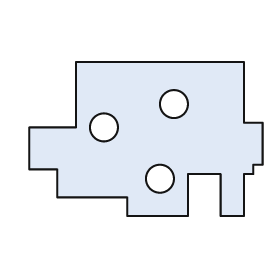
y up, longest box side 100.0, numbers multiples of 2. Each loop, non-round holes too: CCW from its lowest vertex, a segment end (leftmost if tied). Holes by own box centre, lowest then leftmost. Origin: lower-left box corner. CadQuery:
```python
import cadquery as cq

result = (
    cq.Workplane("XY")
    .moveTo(42.0, 0.0)
    .lineTo(68.0, 0.0)
    .lineTo(68.0, 18.0)
    .lineTo(82.0, 18.0)
    .lineTo(82.0, 0.0)
    .lineTo(92.0, 0.0)
    .lineTo(92.0, 18.0)
    .lineTo(96.0, 18.0)
    .lineTo(96.0, 22.0)
    .lineTo(100.0, 22.0)
    .lineTo(100.0, 40.0)
    .lineTo(92.0, 40.0)
    .lineTo(92.0, 66.0)
    .lineTo(20.0, 66.0)
    .lineTo(20.0, 38.0)
    .lineTo(0.0, 38.0)
    .lineTo(0.0, 20.0)
    .lineTo(12.0, 20.0)
    .lineTo(12.0, 8.0)
    .lineTo(42.0, 8.0)
    .close()
    .moveTo(56.0, 16.0)
    .circle(6.0)
    .moveTo(32.0, 38.0)
    .circle(6.0)
    .moveTo(62.0, 48.0)
    .circle(6.0)
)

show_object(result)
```